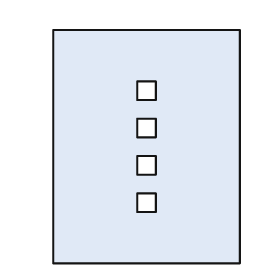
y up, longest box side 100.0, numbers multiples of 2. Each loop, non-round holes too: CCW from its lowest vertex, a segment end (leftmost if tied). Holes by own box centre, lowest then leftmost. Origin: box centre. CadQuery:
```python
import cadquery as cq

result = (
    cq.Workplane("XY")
    .moveTo(-40.0, -50.0)
    .lineTo(40.0, -50.0)
    .lineTo(40.0, 50.0)
    .lineTo(-40.0, 50.0)
    .close()
    .moveTo(-4.0, -28.0)
    .lineTo(4.0, -28.0)
    .lineTo(4.0, -20.0)
    .lineTo(-4.0, -20.0)
    .close()
    .moveTo(-4.0, -12.0)
    .lineTo(4.0, -12.0)
    .lineTo(4.0, -4.0)
    .lineTo(-4.0, -4.0)
    .close()
    .moveTo(-4.0, 4.0)
    .lineTo(4.0, 4.0)
    .lineTo(4.0, 12.0)
    .lineTo(-4.0, 12.0)
    .close()
    .moveTo(-4.0, 20.0)
    .lineTo(4.0, 20.0)
    .lineTo(4.0, 28.0)
    .lineTo(-4.0, 28.0)
    .close()
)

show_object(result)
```